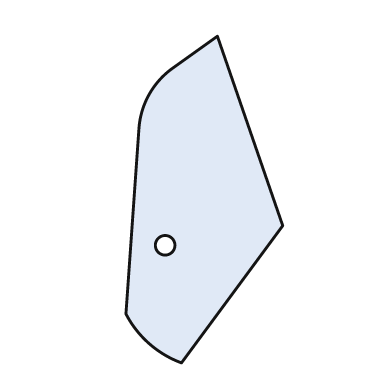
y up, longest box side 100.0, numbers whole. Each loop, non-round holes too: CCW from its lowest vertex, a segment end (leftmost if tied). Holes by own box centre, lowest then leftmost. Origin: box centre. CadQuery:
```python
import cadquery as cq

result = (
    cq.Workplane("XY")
    .moveTo(-7.0, -50.0)
    .lineTo(24.0, -8.0)
    .lineTo(4.0, 50.0)
    .lineTo(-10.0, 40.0)
    .threePointArc((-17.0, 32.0), (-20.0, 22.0))
    .lineTo(-24.0, -35.0)
    .threePointArc((-17.0, -44.0), (-7.0, -50.0))
    .close()
    .moveTo(-12.0, -14.0)
    .circle(3.0)
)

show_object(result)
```